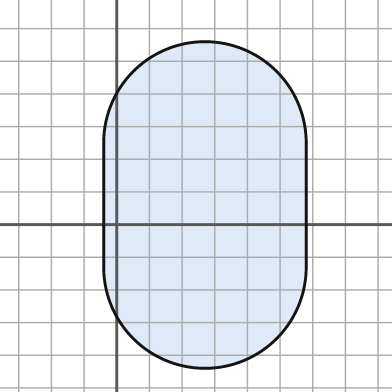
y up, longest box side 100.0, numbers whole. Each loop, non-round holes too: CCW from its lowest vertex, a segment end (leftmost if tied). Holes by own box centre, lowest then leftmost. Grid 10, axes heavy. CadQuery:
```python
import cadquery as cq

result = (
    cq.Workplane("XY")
    .moveTo(-4.0, -13.0)
    .threePointArc((27.0, -44.0), (58.0, -13.0))
    .lineTo(58.0, 25.0)
    .threePointArc((27.0, 56.0), (-4.0, 25.0))
    .close()
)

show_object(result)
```